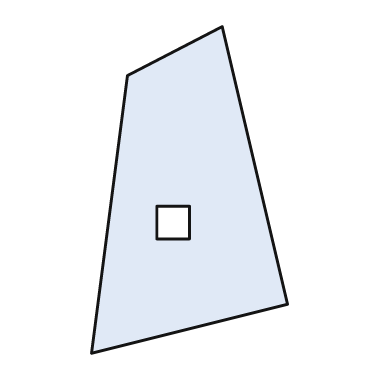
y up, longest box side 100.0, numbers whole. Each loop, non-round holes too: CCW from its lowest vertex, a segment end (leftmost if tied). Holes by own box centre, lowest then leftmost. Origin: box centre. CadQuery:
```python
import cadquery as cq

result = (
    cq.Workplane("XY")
    .moveTo(-30.0, -50.0)
    .lineTo(30.0, -35.0)
    .lineTo(10.0, 50.0)
    .lineTo(-19.0, 35.0)
    .close()
    .moveTo(-10.0, -15.0)
    .lineTo(0.0, -15.0)
    .lineTo(0.0, -5.0)
    .lineTo(-10.0, -5.0)
    .close()
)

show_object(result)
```